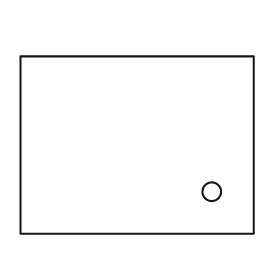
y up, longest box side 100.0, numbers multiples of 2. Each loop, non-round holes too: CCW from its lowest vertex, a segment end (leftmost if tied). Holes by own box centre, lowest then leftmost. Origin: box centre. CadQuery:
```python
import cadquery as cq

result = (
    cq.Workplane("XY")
    .moveTo(-50.0, -38.0)
    .lineTo(50.0, -38.0)
    .lineTo(50.0, 38.0)
    .lineTo(-50.0, 38.0)
    .close()
    .moveTo(32.0, -20.0)
    .circle(4.0)
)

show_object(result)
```